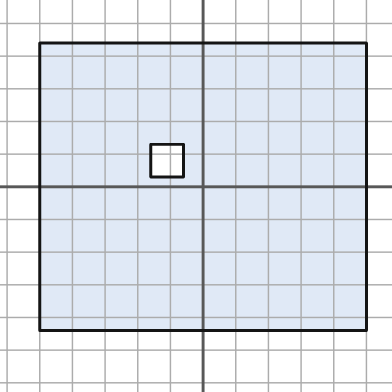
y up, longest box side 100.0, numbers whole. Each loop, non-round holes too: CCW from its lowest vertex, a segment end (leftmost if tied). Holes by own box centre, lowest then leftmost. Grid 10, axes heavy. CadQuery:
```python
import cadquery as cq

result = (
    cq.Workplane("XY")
    .moveTo(-50.0, -44.0)
    .lineTo(50.0, -44.0)
    .lineTo(50.0, 44.0)
    .lineTo(-50.0, 44.0)
    .close()
    .moveTo(-16.0, 3.0)
    .lineTo(-6.0, 3.0)
    .lineTo(-6.0, 13.0)
    .lineTo(-16.0, 13.0)
    .close()
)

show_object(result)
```